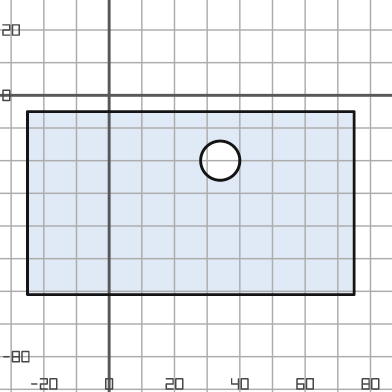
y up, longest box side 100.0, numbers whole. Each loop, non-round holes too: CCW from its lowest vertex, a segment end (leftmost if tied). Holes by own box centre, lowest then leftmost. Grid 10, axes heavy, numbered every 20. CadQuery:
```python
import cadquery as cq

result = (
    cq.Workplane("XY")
    .moveTo(-25.0, -61.0)
    .lineTo(75.0, -61.0)
    .lineTo(75.0, -5.0)
    .lineTo(-25.0, -5.0)
    .close()
    .moveTo(34.0, -20.0)
    .circle(6.0)
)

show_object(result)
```